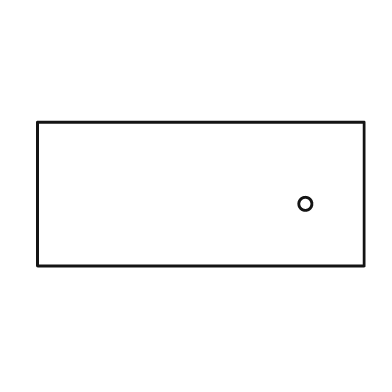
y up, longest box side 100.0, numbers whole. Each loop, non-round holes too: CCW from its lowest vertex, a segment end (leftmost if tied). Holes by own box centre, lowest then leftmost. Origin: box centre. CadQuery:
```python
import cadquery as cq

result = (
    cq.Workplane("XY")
    .moveTo(-50.0, -22.0)
    .lineTo(50.0, -22.0)
    .lineTo(50.0, 22.0)
    .lineTo(-50.0, 22.0)
    .close()
    .moveTo(32.0, -3.0)
    .circle(2.0)
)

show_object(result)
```